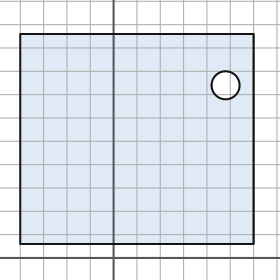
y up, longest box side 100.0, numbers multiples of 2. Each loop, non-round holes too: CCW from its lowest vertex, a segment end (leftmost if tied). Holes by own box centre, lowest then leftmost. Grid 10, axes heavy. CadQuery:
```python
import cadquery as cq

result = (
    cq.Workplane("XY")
    .moveTo(-40.0, 6.0)
    .lineTo(60.0, 6.0)
    .lineTo(60.0, 96.0)
    .lineTo(-40.0, 96.0)
    .close()
    .moveTo(48.0, 74.0)
    .circle(6.0)
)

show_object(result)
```